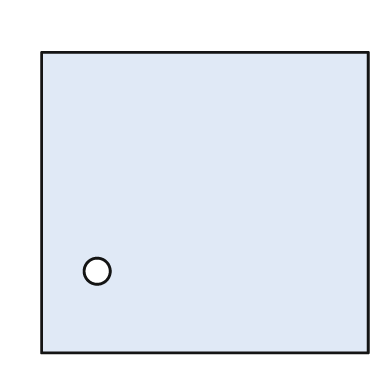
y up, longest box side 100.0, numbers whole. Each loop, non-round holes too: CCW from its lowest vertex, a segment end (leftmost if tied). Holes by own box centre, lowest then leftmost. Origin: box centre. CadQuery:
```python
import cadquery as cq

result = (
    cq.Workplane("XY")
    .moveTo(-50.0, -46.0)
    .lineTo(50.0, -46.0)
    .lineTo(50.0, 46.0)
    .lineTo(-50.0, 46.0)
    .close()
    .moveTo(-33.0, -21.0)
    .circle(4.0)
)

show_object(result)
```